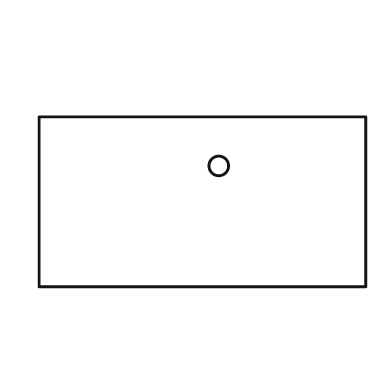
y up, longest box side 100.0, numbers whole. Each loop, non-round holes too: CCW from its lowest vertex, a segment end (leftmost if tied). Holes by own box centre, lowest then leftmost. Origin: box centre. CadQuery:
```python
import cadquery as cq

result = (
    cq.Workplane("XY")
    .moveTo(-50.0, -26.0)
    .lineTo(50.0, -26.0)
    .lineTo(50.0, 26.0)
    .lineTo(-50.0, 26.0)
    .close()
    .moveTo(5.0, 11.0)
    .circle(3.0)
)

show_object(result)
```